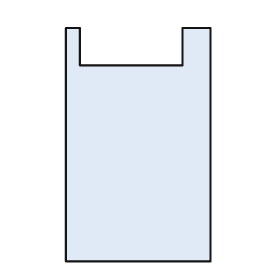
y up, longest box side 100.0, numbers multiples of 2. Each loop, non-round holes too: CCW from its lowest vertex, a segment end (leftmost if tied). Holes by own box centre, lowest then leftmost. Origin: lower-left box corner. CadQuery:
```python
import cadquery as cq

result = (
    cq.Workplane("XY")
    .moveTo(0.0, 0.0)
    .lineTo(62.0, 0.0)
    .lineTo(62.0, 100.0)
    .lineTo(50.0, 100.0)
    .lineTo(50.0, 84.0)
    .lineTo(6.0, 84.0)
    .lineTo(6.0, 100.0)
    .lineTo(0.0, 100.0)
    .close()
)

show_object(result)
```